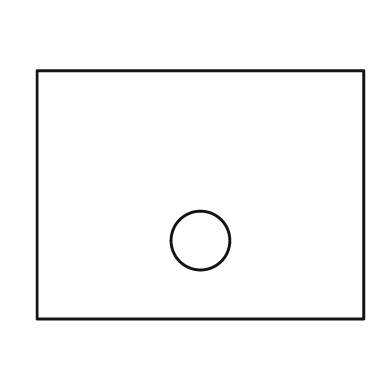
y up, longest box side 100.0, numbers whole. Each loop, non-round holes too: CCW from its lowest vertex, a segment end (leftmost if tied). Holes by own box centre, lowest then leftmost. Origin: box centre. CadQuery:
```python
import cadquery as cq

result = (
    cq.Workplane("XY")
    .moveTo(-50.0, -38.0)
    .lineTo(50.0, -38.0)
    .lineTo(50.0, 38.0)
    .lineTo(-50.0, 38.0)
    .close()
    .moveTo(0.0, -14.0)
    .circle(9.0)
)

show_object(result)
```